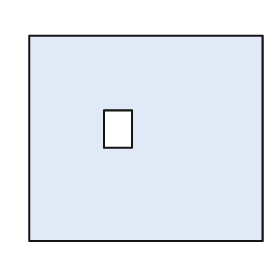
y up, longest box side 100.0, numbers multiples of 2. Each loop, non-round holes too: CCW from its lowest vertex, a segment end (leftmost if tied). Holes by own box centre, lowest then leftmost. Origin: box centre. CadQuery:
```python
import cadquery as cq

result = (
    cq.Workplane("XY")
    .moveTo(-50.0, -44.0)
    .lineTo(50.0, -44.0)
    .lineTo(50.0, 44.0)
    .lineTo(-50.0, 44.0)
    .close()
    .moveTo(-18.0, -4.0)
    .lineTo(-6.0, -4.0)
    .lineTo(-6.0, 12.0)
    .lineTo(-18.0, 12.0)
    .close()
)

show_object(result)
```